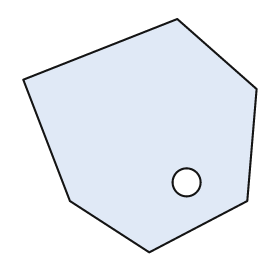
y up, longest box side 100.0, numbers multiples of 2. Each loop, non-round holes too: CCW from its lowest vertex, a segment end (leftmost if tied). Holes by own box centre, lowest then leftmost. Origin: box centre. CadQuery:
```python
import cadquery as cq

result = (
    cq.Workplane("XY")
    .moveTo(4.0, -50.0)
    .lineTo(46.0, -28.0)
    .lineTo(50.0, 20.0)
    .lineTo(16.0, 50.0)
    .lineTo(-50.0, 24.0)
    .lineTo(-30.0, -28.0)
    .close()
    .moveTo(20.0, -20.0)
    .circle(6.0)
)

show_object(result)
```